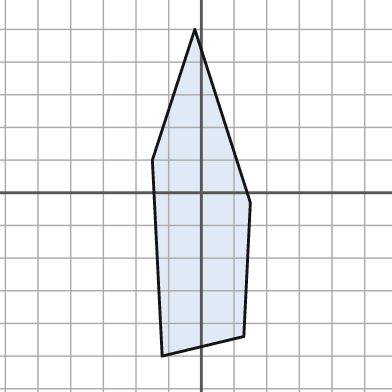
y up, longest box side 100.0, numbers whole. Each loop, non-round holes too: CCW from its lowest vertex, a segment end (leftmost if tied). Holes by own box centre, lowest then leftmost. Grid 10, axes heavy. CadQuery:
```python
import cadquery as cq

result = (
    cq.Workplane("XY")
    .moveTo(-12.0, -50.0)
    .lineTo(13.0, -44.0)
    .lineTo(15.0, -3.0)
    .lineTo(-2.0, 50.0)
    .lineTo(-15.0, 10.0)
    .close()
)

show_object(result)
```